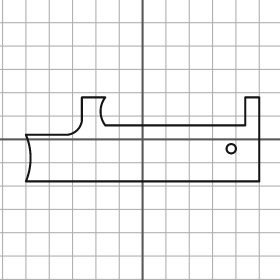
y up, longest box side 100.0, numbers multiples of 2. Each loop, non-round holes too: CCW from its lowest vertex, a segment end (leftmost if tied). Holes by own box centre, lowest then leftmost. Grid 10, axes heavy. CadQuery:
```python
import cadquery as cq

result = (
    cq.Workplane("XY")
    .moveTo(-50.0, -18.0)
    .lineTo(50.0, -18.0)
    .lineTo(50.0, 18.0)
    .lineTo(44.0, 18.0)
    .lineTo(44.0, 6.0)
    .lineTo(-16.0, 6.0)
    .threePointArc((-18.0, 12.0), (-16.0, 18.0))
    .lineTo(-26.0, 18.0)
    .lineTo(-26.0, 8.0)
    .threePointArc((-28.0, 4.0), (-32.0, 2.0))
    .lineTo(-50.0, 2.0)
    .threePointArc((-48.0, -8.0), (-50.0, -18.0))
    .close()
    .moveTo(38.0, -4.0)
    .circle(2.0)
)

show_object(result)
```